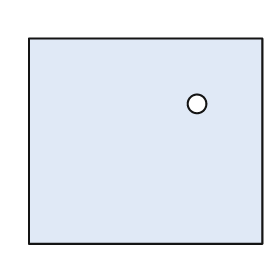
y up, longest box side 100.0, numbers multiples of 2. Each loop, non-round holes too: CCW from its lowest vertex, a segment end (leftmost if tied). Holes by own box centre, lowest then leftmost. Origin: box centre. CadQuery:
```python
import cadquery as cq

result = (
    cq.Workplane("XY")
    .moveTo(-50.0, -44.0)
    .lineTo(50.0, -44.0)
    .lineTo(50.0, 44.0)
    .lineTo(-50.0, 44.0)
    .close()
    .moveTo(22.0, 16.0)
    .circle(4.0)
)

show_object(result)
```